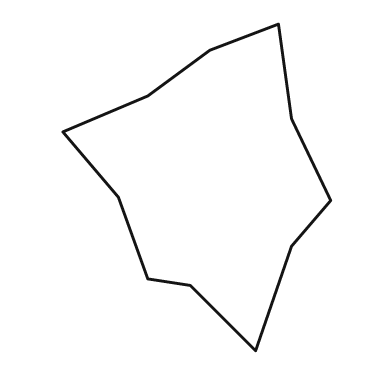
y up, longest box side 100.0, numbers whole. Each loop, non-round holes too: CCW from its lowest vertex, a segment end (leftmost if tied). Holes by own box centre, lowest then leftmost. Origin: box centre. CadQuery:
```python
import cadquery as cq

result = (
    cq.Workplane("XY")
    .moveTo(18.0, -50.0)
    .lineTo(29.0, -18.0)
    .lineTo(41.0, -4.0)
    .lineTo(29.0, 21.0)
    .lineTo(25.0, 50.0)
    .lineTo(4.0, 42.0)
    .lineTo(-15.0, 28.0)
    .lineTo(-41.0, 17.0)
    .lineTo(-24.0, -3.0)
    .lineTo(-15.0, -28.0)
    .lineTo(-2.0, -30.0)
    .close()
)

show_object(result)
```